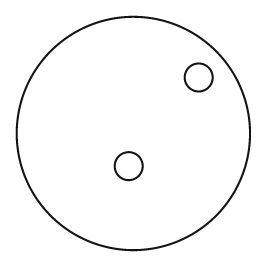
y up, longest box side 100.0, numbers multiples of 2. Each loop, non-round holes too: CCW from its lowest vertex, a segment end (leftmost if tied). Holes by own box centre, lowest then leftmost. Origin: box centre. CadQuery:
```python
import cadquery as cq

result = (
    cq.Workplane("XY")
    .moveTo(0.0, 0.0)
    .circle(50.0)
    .moveTo(-2.0, -14.0)
    .circle(6.0)
    .moveTo(28.0, 24.0)
    .circle(6.0)
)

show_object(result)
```